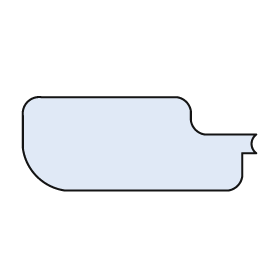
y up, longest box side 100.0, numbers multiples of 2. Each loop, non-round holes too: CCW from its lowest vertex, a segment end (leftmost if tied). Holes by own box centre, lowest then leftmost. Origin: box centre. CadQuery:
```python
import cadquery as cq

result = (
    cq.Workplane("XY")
    .moveTo(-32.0, -20.0)
    .lineTo(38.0, -20.0)
    .threePointArc((42.0, -18.0), (44.0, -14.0))
    .lineTo(44.0, -4.0)
    .lineTo(50.0, -4.0)
    .threePointArc((48.0, 0.0), (50.0, 4.0))
    .lineTo(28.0, 4.0)
    .threePointArc((24.0, 6.0), (22.0, 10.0))
    .lineTo(22.0, 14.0)
    .threePointArc((20.0, 18.0), (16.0, 20.0))
    .lineTo(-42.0, 20.0)
    .threePointArc((-48.0, 18.0), (-50.0, 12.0))
    .lineTo(-50.0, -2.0)
    .threePointArc((-44.0, -14.0), (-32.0, -20.0))
    .close()
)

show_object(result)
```